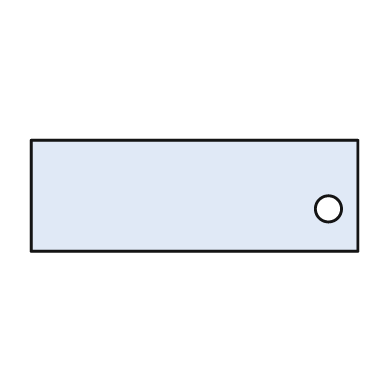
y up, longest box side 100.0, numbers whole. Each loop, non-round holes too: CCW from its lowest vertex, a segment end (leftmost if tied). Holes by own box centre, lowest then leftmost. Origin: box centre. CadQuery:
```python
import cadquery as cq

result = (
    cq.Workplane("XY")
    .moveTo(-50.0, -17.0)
    .lineTo(50.0, -17.0)
    .lineTo(50.0, 17.0)
    .lineTo(-50.0, 17.0)
    .close()
    .moveTo(41.0, -4.0)
    .circle(4.0)
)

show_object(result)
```